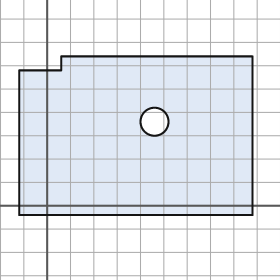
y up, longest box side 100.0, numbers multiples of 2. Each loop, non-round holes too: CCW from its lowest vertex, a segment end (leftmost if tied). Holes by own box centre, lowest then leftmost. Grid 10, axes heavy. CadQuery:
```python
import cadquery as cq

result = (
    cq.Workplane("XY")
    .moveTo(-12.0, -4.0)
    .lineTo(88.0, -4.0)
    .lineTo(88.0, 64.0)
    .lineTo(6.0, 64.0)
    .lineTo(6.0, 58.0)
    .lineTo(-12.0, 58.0)
    .close()
    .moveTo(46.0, 36.0)
    .circle(6.0)
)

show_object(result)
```